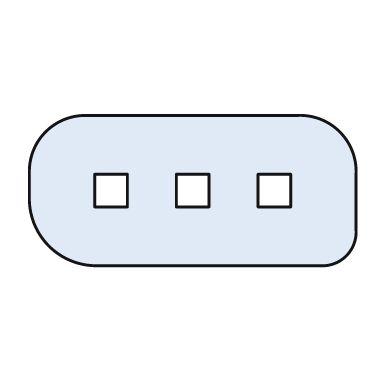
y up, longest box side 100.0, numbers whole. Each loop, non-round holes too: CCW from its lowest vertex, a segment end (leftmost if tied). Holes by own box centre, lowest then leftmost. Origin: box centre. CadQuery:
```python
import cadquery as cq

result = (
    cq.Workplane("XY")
    .moveTo(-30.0, -23.0)
    .lineTo(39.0, -23.0)
    .threePointArc((47.0, -20.0), (50.0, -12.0))
    .lineTo(50.0, 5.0)
    .threePointArc((45.0, 18.0), (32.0, 23.0))
    .lineTo(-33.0, 23.0)
    .threePointArc((-45.0, 18.0), (-50.0, 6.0))
    .lineTo(-50.0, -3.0)
    .threePointArc((-44.0, -17.0), (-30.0, -23.0))
    .close()
    .moveTo(-30.0, -5.0)
    .lineTo(-20.0, -5.0)
    .lineTo(-20.0, 5.0)
    .lineTo(-30.0, 5.0)
    .close()
    .moveTo(-5.0, -5.0)
    .lineTo(5.0, -5.0)
    .lineTo(5.0, 5.0)
    .lineTo(-5.0, 5.0)
    .close()
    .moveTo(20.0, -5.0)
    .lineTo(30.0, -5.0)
    .lineTo(30.0, 5.0)
    .lineTo(20.0, 5.0)
    .close()
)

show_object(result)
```